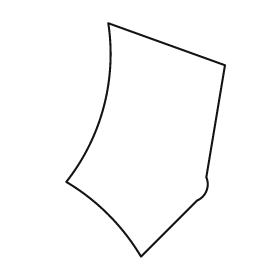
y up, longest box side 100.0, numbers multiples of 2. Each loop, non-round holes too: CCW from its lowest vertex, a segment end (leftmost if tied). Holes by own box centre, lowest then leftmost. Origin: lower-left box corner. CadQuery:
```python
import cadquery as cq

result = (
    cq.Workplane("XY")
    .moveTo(32.0, 0.0)
    .lineTo(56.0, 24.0)
    .threePointArc((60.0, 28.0), (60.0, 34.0))
    .lineTo(68.0, 82.0)
    .lineTo(18.0, 100.0)
    .threePointArc((16.0, 64.0), (0.0, 32.0))
    .threePointArc((18.0, 18.0), (32.0, 0.0))
    .close()
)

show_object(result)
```